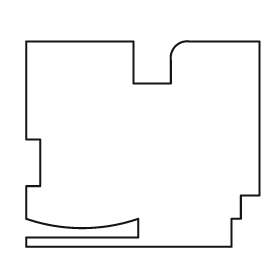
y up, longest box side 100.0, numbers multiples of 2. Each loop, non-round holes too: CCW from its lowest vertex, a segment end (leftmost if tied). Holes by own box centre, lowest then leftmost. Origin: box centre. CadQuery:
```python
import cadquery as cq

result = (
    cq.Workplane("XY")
    .moveTo(-50.0, -44.0)
    .lineTo(38.0, -44.0)
    .lineTo(38.0, -32.0)
    .lineTo(42.0, -32.0)
    .lineTo(42.0, -22.0)
    .lineTo(50.0, -22.0)
    .lineTo(50.0, 44.0)
    .lineTo(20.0, 44.0)
    .threePointArc((14.0, 42.0), (12.0, 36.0))
    .lineTo(12.0, 26.0)
    .lineTo(-4.0, 26.0)
    .lineTo(-4.0, 44.0)
    .lineTo(-50.0, 44.0)
    .lineTo(-50.0, 2.0)
    .lineTo(-44.0, 2.0)
    .lineTo(-44.0, -18.0)
    .lineTo(-50.0, -18.0)
    .lineTo(-50.0, -32.0)
    .threePointArc((-26.0, -36.0), (-2.0, -32.0))
    .lineTo(-2.0, -40.0)
    .lineTo(-50.0, -40.0)
    .close()
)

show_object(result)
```